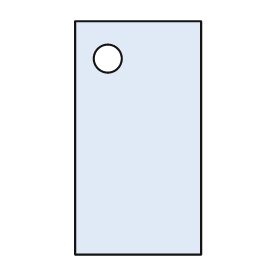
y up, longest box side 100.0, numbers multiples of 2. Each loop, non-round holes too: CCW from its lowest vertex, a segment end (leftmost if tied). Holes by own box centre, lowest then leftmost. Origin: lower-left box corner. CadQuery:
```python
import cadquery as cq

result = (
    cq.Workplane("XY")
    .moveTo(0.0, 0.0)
    .lineTo(54.0, 0.0)
    .lineTo(54.0, 100.0)
    .lineTo(0.0, 100.0)
    .close()
    .moveTo(14.0, 84.0)
    .circle(6.0)
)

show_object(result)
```